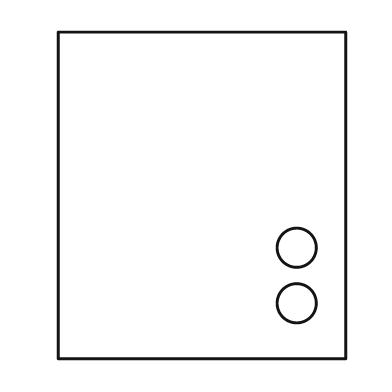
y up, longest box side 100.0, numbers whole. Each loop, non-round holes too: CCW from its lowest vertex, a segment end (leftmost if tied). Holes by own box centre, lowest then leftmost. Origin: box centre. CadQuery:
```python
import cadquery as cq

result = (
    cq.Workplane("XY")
    .moveTo(-44.0, -50.0)
    .lineTo(44.0, -50.0)
    .lineTo(44.0, 50.0)
    .lineTo(-44.0, 50.0)
    .close()
    .moveTo(29.0, -33.0)
    .circle(6.0)
    .moveTo(29.0, -16.0)
    .circle(6.0)
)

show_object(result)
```